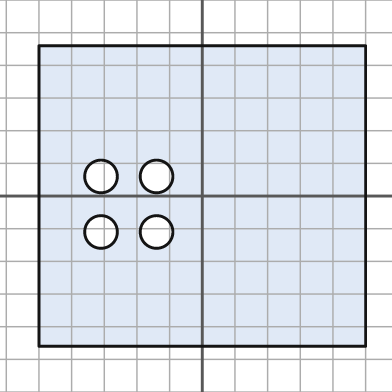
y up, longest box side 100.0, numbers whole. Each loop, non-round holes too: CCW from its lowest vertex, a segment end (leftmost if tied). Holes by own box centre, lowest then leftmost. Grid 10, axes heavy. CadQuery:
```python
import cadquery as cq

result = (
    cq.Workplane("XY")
    .moveTo(-50.0, -46.0)
    .lineTo(50.0, -46.0)
    .lineTo(50.0, 46.0)
    .lineTo(-50.0, 46.0)
    .close()
    .moveTo(-31.0, -11.0)
    .circle(5.0)
    .moveTo(-14.0, -11.0)
    .circle(5.0)
    .moveTo(-31.0, 6.0)
    .circle(5.0)
    .moveTo(-14.0, 6.0)
    .circle(5.0)
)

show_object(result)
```